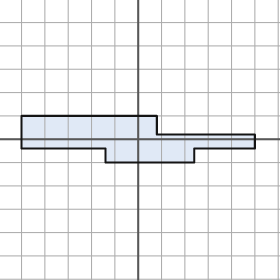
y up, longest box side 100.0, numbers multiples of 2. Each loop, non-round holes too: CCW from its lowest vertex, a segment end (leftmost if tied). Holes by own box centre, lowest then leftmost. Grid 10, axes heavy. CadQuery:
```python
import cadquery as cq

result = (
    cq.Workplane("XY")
    .moveTo(-14.0, -10.0)
    .lineTo(24.0, -10.0)
    .lineTo(24.0, -4.0)
    .lineTo(50.0, -4.0)
    .lineTo(50.0, 2.0)
    .lineTo(8.0, 2.0)
    .lineTo(8.0, 10.0)
    .lineTo(-50.0, 10.0)
    .lineTo(-50.0, -4.0)
    .lineTo(-14.0, -4.0)
    .close()
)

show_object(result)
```